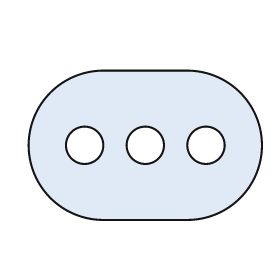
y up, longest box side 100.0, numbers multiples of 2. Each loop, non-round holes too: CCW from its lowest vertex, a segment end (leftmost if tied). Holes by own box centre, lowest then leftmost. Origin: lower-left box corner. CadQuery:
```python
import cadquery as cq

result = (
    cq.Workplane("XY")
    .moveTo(32.0, 0.0)
    .lineTo(68.0, 0.0)
    .threePointArc((100.0, 32.0), (68.0, 64.0))
    .lineTo(32.0, 64.0)
    .threePointArc((0.0, 32.0), (32.0, 0.0))
    .close()
    .moveTo(24.0, 32.0)
    .circle(8.0)
    .moveTo(50.0, 32.0)
    .circle(8.0)
    .moveTo(76.0, 32.0)
    .circle(8.0)
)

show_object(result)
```